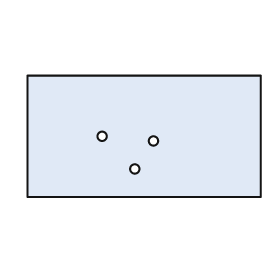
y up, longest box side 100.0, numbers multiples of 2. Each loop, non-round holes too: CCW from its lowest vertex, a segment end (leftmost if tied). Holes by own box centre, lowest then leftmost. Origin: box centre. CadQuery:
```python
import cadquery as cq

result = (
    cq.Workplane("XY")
    .moveTo(-50.0, -26.0)
    .lineTo(50.0, -26.0)
    .lineTo(50.0, 26.0)
    .lineTo(-50.0, 26.0)
    .close()
    .moveTo(-4.0, -14.0)
    .circle(2.0)
    .moveTo(4.0, -2.0)
    .circle(2.0)
    .moveTo(-18.0, 0.0)
    .circle(2.0)
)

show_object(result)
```